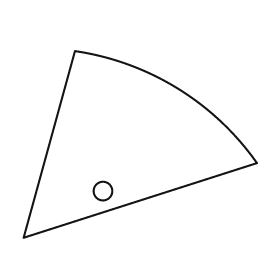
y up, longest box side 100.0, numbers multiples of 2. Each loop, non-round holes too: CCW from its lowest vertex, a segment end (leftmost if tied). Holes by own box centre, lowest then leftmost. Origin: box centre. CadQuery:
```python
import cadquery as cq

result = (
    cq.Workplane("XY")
    .moveTo(-50.0, -40.0)
    .lineTo(50.0, -8.0)
    .threePointArc((16.0, 24.0), (-28.0, 40.0))
    .close()
    .moveTo(-16.0, -20.0)
    .circle(4.0)
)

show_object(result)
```